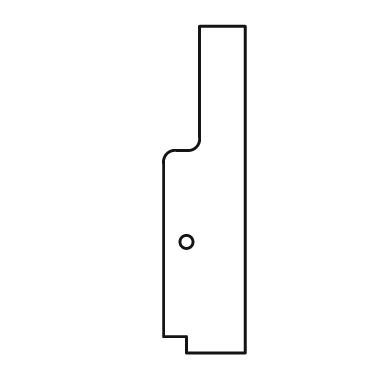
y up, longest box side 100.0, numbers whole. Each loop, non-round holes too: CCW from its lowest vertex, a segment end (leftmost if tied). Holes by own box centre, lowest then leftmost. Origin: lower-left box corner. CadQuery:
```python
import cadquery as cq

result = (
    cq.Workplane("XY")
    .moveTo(7.0, 0.0)
    .lineTo(25.0, 0.0)
    .lineTo(25.0, 100.0)
    .lineTo(11.0, 100.0)
    .lineTo(11.0, 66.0)
    .threePointArc((10.0, 63.0), (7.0, 62.0))
    .lineTo(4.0, 62.0)
    .threePointArc((1.0, 61.0), (0.0, 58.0))
    .lineTo(0.0, 5.0)
    .lineTo(7.0, 5.0)
    .close()
    .moveTo(7.0, 34.0)
    .circle(2.0)
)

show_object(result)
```